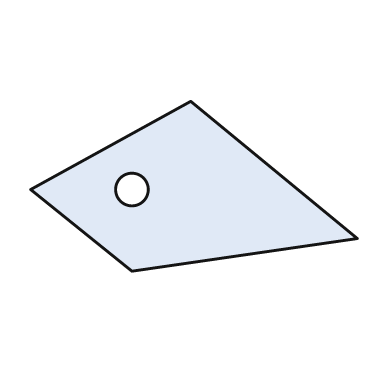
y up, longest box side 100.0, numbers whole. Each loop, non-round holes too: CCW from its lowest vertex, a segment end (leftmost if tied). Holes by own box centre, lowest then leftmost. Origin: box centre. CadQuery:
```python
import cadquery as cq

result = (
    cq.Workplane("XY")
    .moveTo(-19.0, -26.0)
    .lineTo(50.0, -16.0)
    .lineTo(-1.0, 26.0)
    .lineTo(-50.0, -1.0)
    .close()
    .moveTo(-19.0, -1.0)
    .circle(5.0)
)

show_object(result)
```